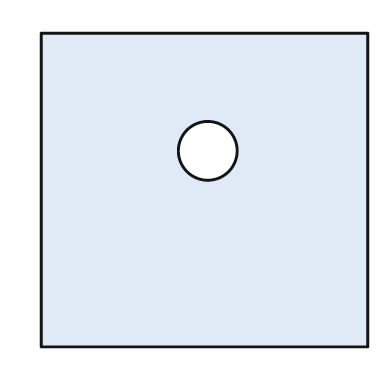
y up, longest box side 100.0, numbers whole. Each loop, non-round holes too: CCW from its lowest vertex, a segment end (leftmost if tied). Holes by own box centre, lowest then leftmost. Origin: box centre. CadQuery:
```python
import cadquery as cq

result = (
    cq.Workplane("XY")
    .moveTo(-50.0, -48.0)
    .lineTo(50.0, -48.0)
    .lineTo(50.0, 48.0)
    .lineTo(-50.0, 48.0)
    .close()
    .moveTo(1.0, 12.0)
    .circle(9.0)
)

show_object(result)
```